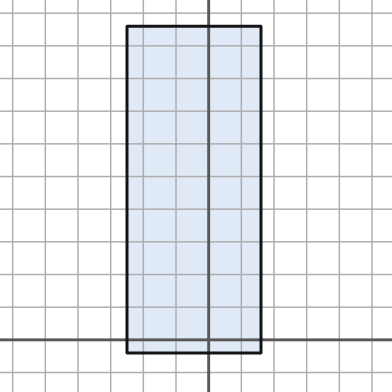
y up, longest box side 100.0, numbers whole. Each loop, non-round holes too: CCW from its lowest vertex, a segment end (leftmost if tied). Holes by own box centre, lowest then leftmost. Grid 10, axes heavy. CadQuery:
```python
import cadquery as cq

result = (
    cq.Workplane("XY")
    .moveTo(-25.0, -4.0)
    .lineTo(16.0, -4.0)
    .lineTo(16.0, 96.0)
    .lineTo(-25.0, 96.0)
    .close()
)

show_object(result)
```